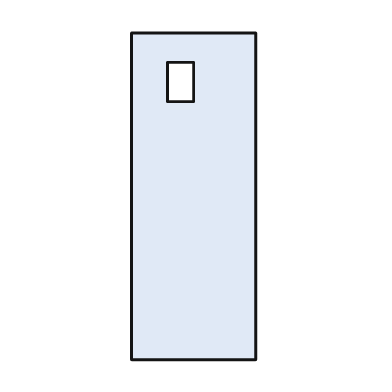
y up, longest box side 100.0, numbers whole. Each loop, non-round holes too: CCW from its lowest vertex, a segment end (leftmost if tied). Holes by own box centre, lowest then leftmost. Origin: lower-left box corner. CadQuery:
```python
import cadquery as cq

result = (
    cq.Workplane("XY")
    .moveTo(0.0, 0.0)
    .lineTo(38.0, 0.0)
    .lineTo(38.0, 100.0)
    .lineTo(0.0, 100.0)
    .close()
    .moveTo(11.0, 79.0)
    .lineTo(19.0, 79.0)
    .lineTo(19.0, 91.0)
    .lineTo(11.0, 91.0)
    .close()
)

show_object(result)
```